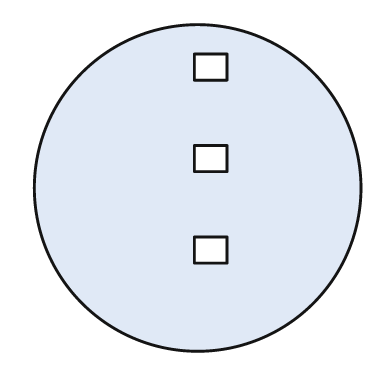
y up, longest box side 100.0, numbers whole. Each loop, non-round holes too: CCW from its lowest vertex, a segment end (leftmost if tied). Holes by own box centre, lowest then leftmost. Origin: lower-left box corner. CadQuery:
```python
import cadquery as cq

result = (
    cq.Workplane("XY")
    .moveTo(50.0, 50.0)
    .circle(50.0)
    .moveTo(49.0, 27.0)
    .lineTo(59.0, 27.0)
    .lineTo(59.0, 35.0)
    .lineTo(49.0, 35.0)
    .close()
    .moveTo(49.0, 55.0)
    .lineTo(59.0, 55.0)
    .lineTo(59.0, 63.0)
    .lineTo(49.0, 63.0)
    .close()
    .moveTo(49.0, 83.0)
    .lineTo(59.0, 83.0)
    .lineTo(59.0, 91.0)
    .lineTo(49.0, 91.0)
    .close()
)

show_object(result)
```